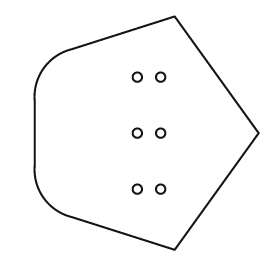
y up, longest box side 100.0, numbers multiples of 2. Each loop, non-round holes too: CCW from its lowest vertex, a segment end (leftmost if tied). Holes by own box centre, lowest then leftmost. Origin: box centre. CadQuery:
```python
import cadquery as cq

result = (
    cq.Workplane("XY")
    .moveTo(12.0, -50.0)
    .lineTo(48.0, 0.0)
    .lineTo(12.0, 50.0)
    .lineTo(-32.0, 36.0)
    .threePointArc((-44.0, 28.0), (-48.0, 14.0))
    .lineTo(-48.0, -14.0)
    .threePointArc((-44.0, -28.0), (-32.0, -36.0))
    .close()
    .moveTo(-4.0, -24.0)
    .circle(2.0)
    .moveTo(6.0, -24.0)
    .circle(2.0)
    .moveTo(-4.0, 0.0)
    .circle(2.0)
    .moveTo(6.0, 0.0)
    .circle(2.0)
    .moveTo(-4.0, 24.0)
    .circle(2.0)
    .moveTo(6.0, 24.0)
    .circle(2.0)
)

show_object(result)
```